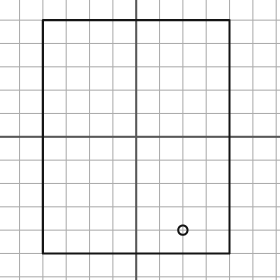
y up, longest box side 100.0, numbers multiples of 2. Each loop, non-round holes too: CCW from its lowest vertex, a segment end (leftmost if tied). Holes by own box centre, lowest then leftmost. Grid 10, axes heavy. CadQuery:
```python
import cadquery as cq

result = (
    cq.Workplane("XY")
    .moveTo(-40.0, -50.0)
    .lineTo(40.0, -50.0)
    .lineTo(40.0, 50.0)
    .lineTo(-40.0, 50.0)
    .close()
    .moveTo(20.0, -40.0)
    .circle(2.0)
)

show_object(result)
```